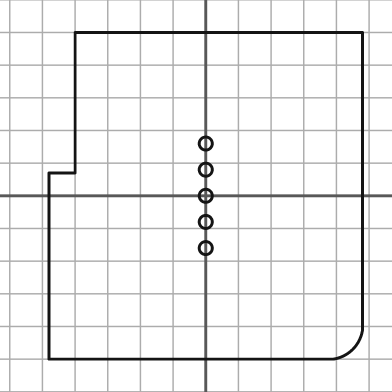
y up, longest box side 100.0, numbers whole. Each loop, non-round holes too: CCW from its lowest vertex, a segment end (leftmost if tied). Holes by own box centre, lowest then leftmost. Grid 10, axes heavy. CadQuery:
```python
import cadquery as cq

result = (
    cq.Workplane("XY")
    .moveTo(-48.0, -50.0)
    .lineTo(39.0, -50.0)
    .threePointArc((45.0, -47.0), (48.0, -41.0))
    .lineTo(48.0, 50.0)
    .lineTo(-40.0, 50.0)
    .lineTo(-40.0, 7.0)
    .lineTo(-48.0, 7.0)
    .close()
    .moveTo(0.0, -16.0)
    .circle(2.0)
    .moveTo(0.0, -8.0)
    .circle(2.0)
    .moveTo(0.0, 0.0)
    .circle(2.0)
    .moveTo(0.0, 8.0)
    .circle(2.0)
    .moveTo(0.0, 16.0)
    .circle(2.0)
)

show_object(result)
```